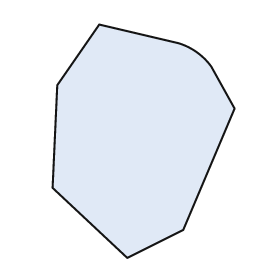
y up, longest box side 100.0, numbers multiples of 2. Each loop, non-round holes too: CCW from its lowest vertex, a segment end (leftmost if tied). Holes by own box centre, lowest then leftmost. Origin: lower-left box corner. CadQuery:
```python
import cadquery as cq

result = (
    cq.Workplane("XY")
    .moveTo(32.0, 0.0)
    .lineTo(56.0, 12.0)
    .lineTo(78.0, 64.0)
    .lineTo(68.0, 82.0)
    .threePointArc((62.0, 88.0), (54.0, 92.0))
    .lineTo(20.0, 100.0)
    .lineTo(2.0, 74.0)
    .lineTo(0.0, 30.0)
    .close()
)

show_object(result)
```